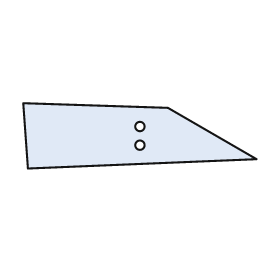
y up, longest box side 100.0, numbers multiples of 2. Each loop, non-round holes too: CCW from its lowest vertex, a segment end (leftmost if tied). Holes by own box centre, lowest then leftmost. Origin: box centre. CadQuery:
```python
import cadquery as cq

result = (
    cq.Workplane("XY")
    .moveTo(-48.0, -14.0)
    .lineTo(50.0, -10.0)
    .lineTo(12.0, 12.0)
    .lineTo(-50.0, 14.0)
    .close()
    .moveTo(0.0, -4.0)
    .circle(2.0)
    .moveTo(0.0, 4.0)
    .circle(2.0)
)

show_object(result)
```